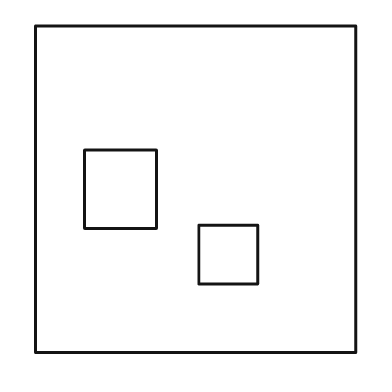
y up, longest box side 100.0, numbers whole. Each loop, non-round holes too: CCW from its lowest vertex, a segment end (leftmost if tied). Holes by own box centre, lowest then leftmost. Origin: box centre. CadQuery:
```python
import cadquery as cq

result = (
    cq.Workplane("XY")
    .moveTo(-49.0, -50.0)
    .lineTo(49.0, -50.0)
    .lineTo(49.0, 50.0)
    .lineTo(-49.0, 50.0)
    .close()
    .moveTo(1.0, -29.0)
    .lineTo(19.0, -29.0)
    .lineTo(19.0, -11.0)
    .lineTo(1.0, -11.0)
    .close()
    .moveTo(-34.0, -12.0)
    .lineTo(-12.0, -12.0)
    .lineTo(-12.0, 12.0)
    .lineTo(-34.0, 12.0)
    .close()
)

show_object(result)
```